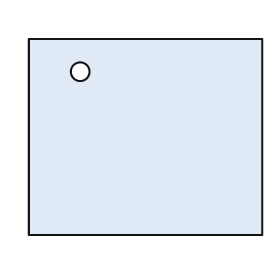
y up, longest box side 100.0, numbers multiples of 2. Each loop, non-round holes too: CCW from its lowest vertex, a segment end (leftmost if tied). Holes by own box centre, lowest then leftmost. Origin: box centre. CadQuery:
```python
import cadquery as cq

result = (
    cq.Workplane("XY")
    .moveTo(-50.0, -42.0)
    .lineTo(50.0, -42.0)
    .lineTo(50.0, 42.0)
    .lineTo(-50.0, 42.0)
    .close()
    .moveTo(-28.0, 28.0)
    .circle(4.0)
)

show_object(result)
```